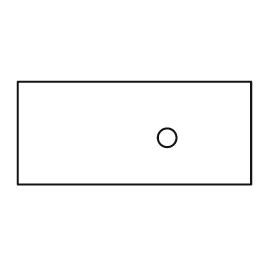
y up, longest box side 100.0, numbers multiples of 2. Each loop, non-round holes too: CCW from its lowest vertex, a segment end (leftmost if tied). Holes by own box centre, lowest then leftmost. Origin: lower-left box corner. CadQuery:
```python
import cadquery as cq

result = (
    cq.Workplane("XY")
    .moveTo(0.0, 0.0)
    .lineTo(100.0, 0.0)
    .lineTo(100.0, 44.0)
    .lineTo(0.0, 44.0)
    .close()
    .moveTo(64.0, 20.0)
    .circle(4.0)
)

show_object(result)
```